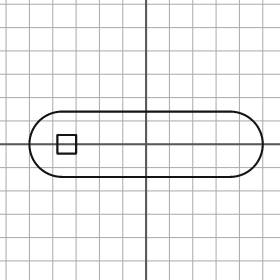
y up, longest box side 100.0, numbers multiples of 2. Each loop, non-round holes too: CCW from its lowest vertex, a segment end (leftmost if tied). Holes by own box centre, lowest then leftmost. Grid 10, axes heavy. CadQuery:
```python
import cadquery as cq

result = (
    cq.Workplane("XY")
    .moveTo(-36.0, -14.0)
    .lineTo(36.0, -14.0)
    .threePointArc((50.0, 0.0), (36.0, 14.0))
    .lineTo(-36.0, 14.0)
    .threePointArc((-50.0, 0.0), (-36.0, -14.0))
    .close()
    .moveTo(-38.0, -4.0)
    .lineTo(-30.0, -4.0)
    .lineTo(-30.0, 4.0)
    .lineTo(-38.0, 4.0)
    .close()
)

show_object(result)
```